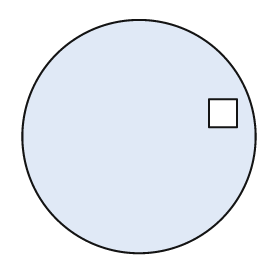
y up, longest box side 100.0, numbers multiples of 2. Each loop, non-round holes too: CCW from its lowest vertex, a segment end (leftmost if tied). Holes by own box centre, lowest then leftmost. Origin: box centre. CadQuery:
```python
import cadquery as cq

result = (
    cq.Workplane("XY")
    .moveTo(0.0, 0.0)
    .circle(50.0)
    .moveTo(30.0, 4.0)
    .lineTo(42.0, 4.0)
    .lineTo(42.0, 16.0)
    .lineTo(30.0, 16.0)
    .close()
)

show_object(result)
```